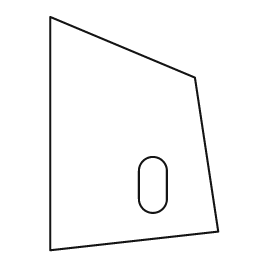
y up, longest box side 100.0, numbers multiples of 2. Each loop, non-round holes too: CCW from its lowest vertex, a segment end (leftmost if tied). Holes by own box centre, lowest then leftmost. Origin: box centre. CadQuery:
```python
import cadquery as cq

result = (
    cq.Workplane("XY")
    .moveTo(-36.0, -50.0)
    .lineTo(36.0, -42.0)
    .lineTo(26.0, 24.0)
    .lineTo(-36.0, 50.0)
    .close()
    .moveTo(2.0, -28.0)
    .threePointArc((8.0, -34.0), (14.0, -28.0))
    .lineTo(14.0, -16.0)
    .threePointArc((8.0, -10.0), (2.0, -16.0))
    .close()
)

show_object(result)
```